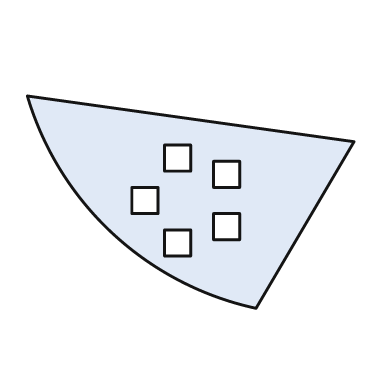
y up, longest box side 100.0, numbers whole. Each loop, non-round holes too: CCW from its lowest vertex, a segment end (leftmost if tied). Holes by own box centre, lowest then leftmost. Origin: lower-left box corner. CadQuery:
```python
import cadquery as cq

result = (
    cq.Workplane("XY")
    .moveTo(70.0, 0.0)
    .lineTo(100.0, 51.0)
    .lineTo(0.0, 65.0)
    .threePointArc((26.0, 23.0), (70.0, 0.0))
    .close()
    .moveTo(42.0, 16.0)
    .lineTo(50.0, 16.0)
    .lineTo(50.0, 24.0)
    .lineTo(42.0, 24.0)
    .close()
    .moveTo(57.0, 21.0)
    .lineTo(65.0, 21.0)
    .lineTo(65.0, 29.0)
    .lineTo(57.0, 29.0)
    .close()
    .moveTo(32.0, 29.0)
    .lineTo(40.0, 29.0)
    .lineTo(40.0, 37.0)
    .lineTo(32.0, 37.0)
    .close()
    .moveTo(57.0, 37.0)
    .lineTo(65.0, 37.0)
    .lineTo(65.0, 45.0)
    .lineTo(57.0, 45.0)
    .close()
    .moveTo(42.0, 42.0)
    .lineTo(50.0, 42.0)
    .lineTo(50.0, 50.0)
    .lineTo(42.0, 50.0)
    .close()
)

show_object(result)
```